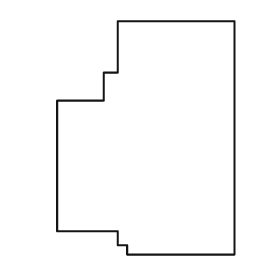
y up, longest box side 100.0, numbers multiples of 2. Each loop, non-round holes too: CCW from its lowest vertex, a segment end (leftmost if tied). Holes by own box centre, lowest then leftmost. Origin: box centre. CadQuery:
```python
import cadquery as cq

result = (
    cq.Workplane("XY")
    .moveTo(-8.0, -50.0)
    .lineTo(38.0, -50.0)
    .lineTo(38.0, 50.0)
    .lineTo(-12.0, 50.0)
    .lineTo(-12.0, 28.0)
    .lineTo(-18.0, 28.0)
    .lineTo(-18.0, 16.0)
    .lineTo(-38.0, 16.0)
    .lineTo(-38.0, -40.0)
    .lineTo(-12.0, -40.0)
    .lineTo(-12.0, -46.0)
    .lineTo(-8.0, -46.0)
    .close()
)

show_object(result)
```